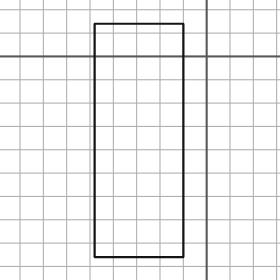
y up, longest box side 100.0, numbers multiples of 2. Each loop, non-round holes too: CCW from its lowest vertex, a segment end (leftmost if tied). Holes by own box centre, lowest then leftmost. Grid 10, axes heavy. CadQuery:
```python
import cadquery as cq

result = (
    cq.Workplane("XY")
    .moveTo(-48.0, -86.0)
    .lineTo(-10.0, -86.0)
    .lineTo(-10.0, 14.0)
    .lineTo(-48.0, 14.0)
    .close()
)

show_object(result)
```